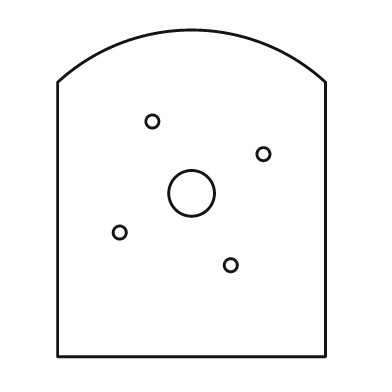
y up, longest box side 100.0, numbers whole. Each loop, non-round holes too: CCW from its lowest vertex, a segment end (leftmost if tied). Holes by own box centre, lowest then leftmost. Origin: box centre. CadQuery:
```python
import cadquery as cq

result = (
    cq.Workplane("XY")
    .moveTo(-41.0, -50.0)
    .lineTo(41.0, -50.0)
    .lineTo(41.0, 34.0)
    .threePointArc((0.0, 50.0), (-41.0, 34.0))
    .close()
    .moveTo(12.0, -22.0)
    .circle(2.0)
    .moveTo(-22.0, -12.0)
    .circle(2.0)
    .moveTo(0.0, 0.0)
    .circle(7.0)
    .moveTo(22.0, 12.0)
    .circle(2.0)
    .moveTo(-12.0, 22.0)
    .circle(2.0)
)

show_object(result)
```